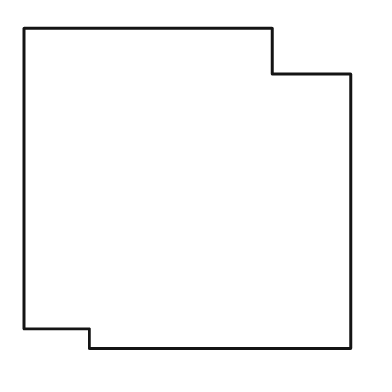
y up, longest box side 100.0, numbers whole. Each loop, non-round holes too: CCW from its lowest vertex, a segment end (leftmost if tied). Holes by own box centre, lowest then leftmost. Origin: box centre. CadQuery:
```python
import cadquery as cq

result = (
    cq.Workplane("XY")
    .moveTo(-30.0, -49.0)
    .lineTo(50.0, -49.0)
    .lineTo(50.0, 35.0)
    .lineTo(26.0, 35.0)
    .lineTo(26.0, 49.0)
    .lineTo(-50.0, 49.0)
    .lineTo(-50.0, -43.0)
    .lineTo(-30.0, -43.0)
    .close()
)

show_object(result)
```